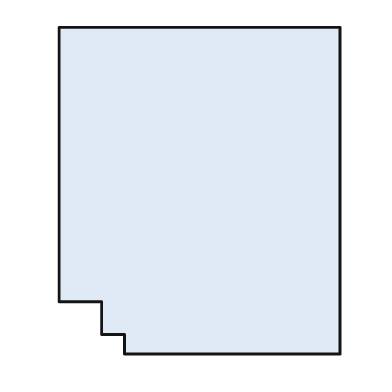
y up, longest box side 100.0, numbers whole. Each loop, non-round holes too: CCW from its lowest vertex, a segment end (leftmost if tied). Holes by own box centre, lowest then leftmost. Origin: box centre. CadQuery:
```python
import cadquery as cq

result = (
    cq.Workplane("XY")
    .moveTo(-23.0, -50.0)
    .lineTo(43.0, -50.0)
    .lineTo(43.0, 50.0)
    .lineTo(-43.0, 50.0)
    .lineTo(-43.0, -34.0)
    .lineTo(-30.0, -34.0)
    .lineTo(-30.0, -44.0)
    .lineTo(-23.0, -44.0)
    .close()
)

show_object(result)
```